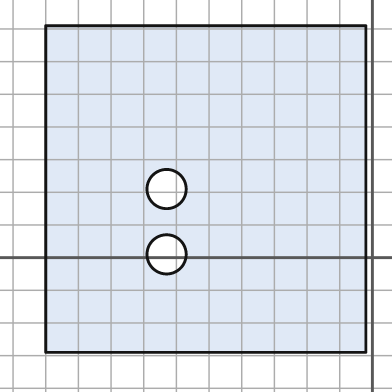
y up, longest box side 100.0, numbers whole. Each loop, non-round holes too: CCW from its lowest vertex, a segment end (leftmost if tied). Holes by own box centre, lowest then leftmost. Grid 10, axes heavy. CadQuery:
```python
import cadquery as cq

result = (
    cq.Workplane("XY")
    .moveTo(-100.0, -29.0)
    .lineTo(-2.0, -29.0)
    .lineTo(-2.0, 71.0)
    .lineTo(-100.0, 71.0)
    .close()
    .moveTo(-63.0, 1.0)
    .circle(6.0)
    .moveTo(-63.0, 21.0)
    .circle(6.0)
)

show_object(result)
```